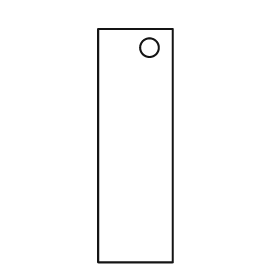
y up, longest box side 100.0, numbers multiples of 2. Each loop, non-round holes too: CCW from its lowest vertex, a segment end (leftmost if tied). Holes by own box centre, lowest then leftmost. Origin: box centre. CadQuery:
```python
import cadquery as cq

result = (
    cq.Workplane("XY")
    .moveTo(-16.0, -50.0)
    .lineTo(16.0, -50.0)
    .lineTo(16.0, 50.0)
    .lineTo(-16.0, 50.0)
    .close()
    .moveTo(6.0, 42.0)
    .circle(4.0)
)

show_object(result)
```